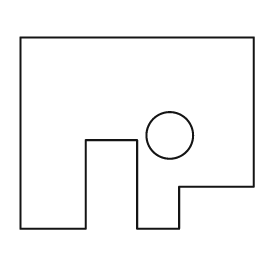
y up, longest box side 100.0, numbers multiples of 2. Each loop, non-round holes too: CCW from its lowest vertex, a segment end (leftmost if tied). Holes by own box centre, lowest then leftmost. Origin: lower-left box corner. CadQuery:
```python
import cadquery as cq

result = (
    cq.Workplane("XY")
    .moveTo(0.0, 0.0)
    .lineTo(28.0, 0.0)
    .lineTo(28.0, 38.0)
    .lineTo(50.0, 38.0)
    .lineTo(50.0, 0.0)
    .lineTo(68.0, 0.0)
    .lineTo(68.0, 18.0)
    .lineTo(100.0, 18.0)
    .lineTo(100.0, 82.0)
    .lineTo(0.0, 82.0)
    .close()
    .moveTo(64.0, 40.0)
    .circle(10.0)
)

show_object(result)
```